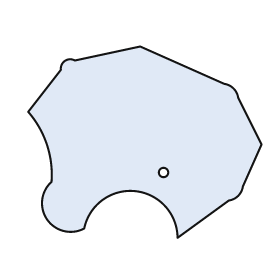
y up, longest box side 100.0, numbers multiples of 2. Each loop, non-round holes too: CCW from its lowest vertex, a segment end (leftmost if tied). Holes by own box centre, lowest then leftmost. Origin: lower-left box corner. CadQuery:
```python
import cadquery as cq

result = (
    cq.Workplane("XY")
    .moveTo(64.0, 0.0)
    .lineTo(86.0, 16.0)
    .threePointArc((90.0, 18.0), (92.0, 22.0))
    .lineTo(100.0, 40.0)
    .lineTo(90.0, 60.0)
    .threePointArc((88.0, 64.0), (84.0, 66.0))
    .lineTo(48.0, 82.0)
    .lineTo(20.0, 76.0)
    .threePointArc((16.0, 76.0), (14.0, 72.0))
    .lineTo(0.0, 54.0)
    .threePointArc((8.0, 40.0), (10.0, 24.0))
    .threePointArc((8.0, 8.0), (24.0, 4.0))
    .threePointArc((46.0, 20.0), (64.0, 0.0))
    .close()
    .moveTo(58.0, 28.0)
    .circle(2.0)
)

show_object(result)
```